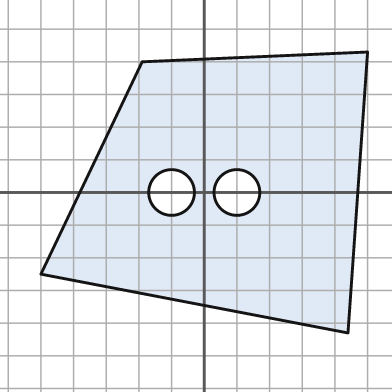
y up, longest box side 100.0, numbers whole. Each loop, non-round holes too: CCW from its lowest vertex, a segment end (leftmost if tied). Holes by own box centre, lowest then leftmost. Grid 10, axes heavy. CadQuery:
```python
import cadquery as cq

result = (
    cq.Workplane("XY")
    .moveTo(44.0, -43.0)
    .lineTo(50.0, 43.0)
    .lineTo(-19.0, 40.0)
    .lineTo(-50.0, -25.0)
    .close()
    .moveTo(-10.0, 0.0)
    .circle(7.0)
    .moveTo(10.0, 0.0)
    .circle(7.0)
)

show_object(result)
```